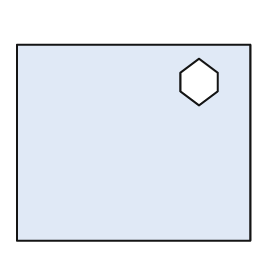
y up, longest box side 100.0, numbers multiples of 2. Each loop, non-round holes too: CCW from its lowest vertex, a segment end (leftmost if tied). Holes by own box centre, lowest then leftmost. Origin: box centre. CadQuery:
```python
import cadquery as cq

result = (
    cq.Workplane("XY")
    .moveTo(-50.0, -42.0)
    .lineTo(50.0, -42.0)
    .lineTo(50.0, 42.0)
    .lineTo(-50.0, 42.0)
    .close()
    .moveTo(28.0, 16.0)
    .lineTo(36.0, 22.0)
    .lineTo(36.0, 30.0)
    .lineTo(28.0, 36.0)
    .lineTo(20.0, 30.0)
    .lineTo(20.0, 22.0)
    .close()
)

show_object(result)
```